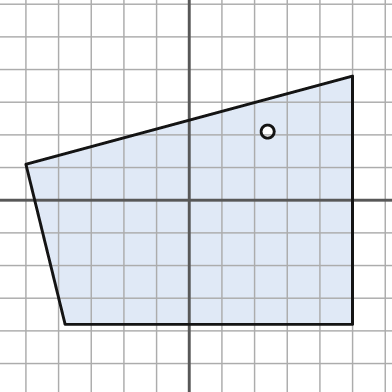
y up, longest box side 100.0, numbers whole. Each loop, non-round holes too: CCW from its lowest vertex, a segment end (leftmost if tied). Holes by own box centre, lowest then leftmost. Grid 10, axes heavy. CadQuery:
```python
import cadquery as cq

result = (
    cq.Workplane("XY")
    .moveTo(-38.0, -38.0)
    .lineTo(50.0, -38.0)
    .lineTo(50.0, 38.0)
    .lineTo(-50.0, 11.0)
    .close()
    .moveTo(24.0, 21.0)
    .circle(2.0)
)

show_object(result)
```